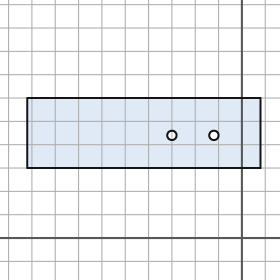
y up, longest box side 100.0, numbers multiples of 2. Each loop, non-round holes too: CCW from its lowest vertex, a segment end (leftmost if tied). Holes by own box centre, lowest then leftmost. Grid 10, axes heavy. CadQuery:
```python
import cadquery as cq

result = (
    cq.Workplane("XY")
    .moveTo(-92.0, 30.0)
    .lineTo(8.0, 30.0)
    .lineTo(8.0, 60.0)
    .lineTo(-92.0, 60.0)
    .close()
    .moveTo(-30.0, 44.0)
    .circle(2.0)
    .moveTo(-12.0, 44.0)
    .circle(2.0)
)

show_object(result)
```